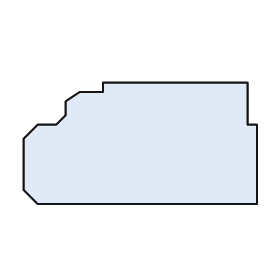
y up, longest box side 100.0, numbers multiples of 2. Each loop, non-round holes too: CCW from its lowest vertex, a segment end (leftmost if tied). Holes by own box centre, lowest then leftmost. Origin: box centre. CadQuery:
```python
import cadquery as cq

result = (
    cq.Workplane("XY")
    .moveTo(-44.0, -26.0)
    .lineTo(50.0, -26.0)
    .lineTo(50.0, 8.0)
    .lineTo(46.0, 8.0)
    .lineTo(46.0, 26.0)
    .lineTo(-16.0, 26.0)
    .lineTo(-16.0, 22.0)
    .lineTo(-26.0, 22.0)
    .lineTo(-32.0, 18.0)
    .lineTo(-32.0, 12.0)
    .lineTo(-36.0, 8.0)
    .lineTo(-44.0, 8.0)
    .lineTo(-50.0, 2.0)
    .lineTo(-50.0, -20.0)
    .close()
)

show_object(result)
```